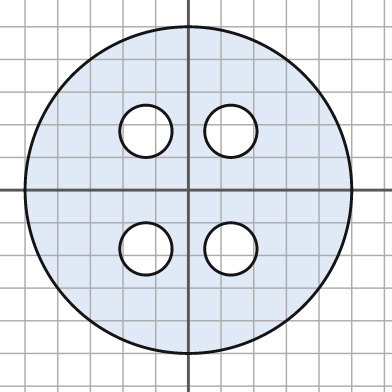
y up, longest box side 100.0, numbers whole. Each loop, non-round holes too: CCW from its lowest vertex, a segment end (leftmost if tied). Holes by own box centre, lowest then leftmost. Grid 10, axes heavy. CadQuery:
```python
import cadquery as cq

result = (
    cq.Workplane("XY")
    .moveTo(0.0, 0.0)
    .circle(50.0)
    .moveTo(-13.0, -18.0)
    .circle(8.0)
    .moveTo(13.0, -18.0)
    .circle(8.0)
    .moveTo(-13.0, 18.0)
    .circle(8.0)
    .moveTo(13.0, 18.0)
    .circle(8.0)
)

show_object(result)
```